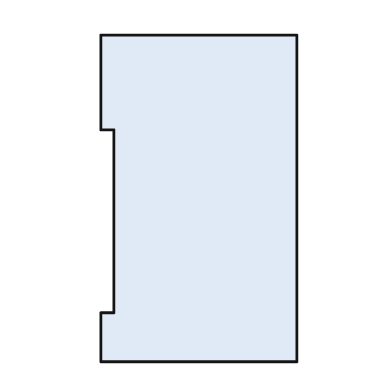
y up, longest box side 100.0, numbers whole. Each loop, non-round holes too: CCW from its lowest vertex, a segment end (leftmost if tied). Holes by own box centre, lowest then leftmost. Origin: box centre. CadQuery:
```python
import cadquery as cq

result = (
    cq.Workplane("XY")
    .moveTo(-30.0, -50.0)
    .lineTo(30.0, -50.0)
    .lineTo(30.0, 50.0)
    .lineTo(-30.0, 50.0)
    .lineTo(-30.0, 21.0)
    .lineTo(-26.0, 21.0)
    .lineTo(-26.0, -35.0)
    .lineTo(-30.0, -35.0)
    .close()
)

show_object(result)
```